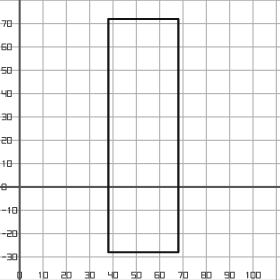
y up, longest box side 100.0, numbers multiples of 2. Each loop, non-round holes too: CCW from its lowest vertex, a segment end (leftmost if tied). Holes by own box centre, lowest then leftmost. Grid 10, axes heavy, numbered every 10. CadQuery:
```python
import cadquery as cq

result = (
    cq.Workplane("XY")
    .moveTo(38.0, -28.0)
    .lineTo(68.0, -28.0)
    .lineTo(68.0, 72.0)
    .lineTo(38.0, 72.0)
    .close()
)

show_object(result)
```